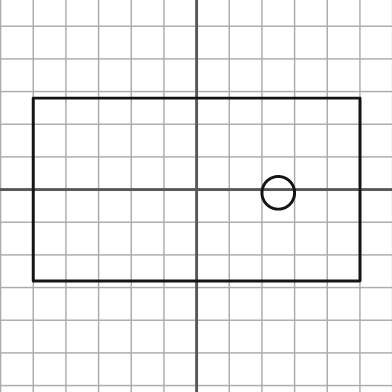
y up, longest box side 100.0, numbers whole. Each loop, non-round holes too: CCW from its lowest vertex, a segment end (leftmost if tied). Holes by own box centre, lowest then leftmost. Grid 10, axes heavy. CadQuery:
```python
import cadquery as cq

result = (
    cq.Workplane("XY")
    .moveTo(-50.0, -28.0)
    .lineTo(50.0, -28.0)
    .lineTo(50.0, 28.0)
    .lineTo(-50.0, 28.0)
    .close()
    .moveTo(25.0, -1.0)
    .circle(5.0)
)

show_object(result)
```